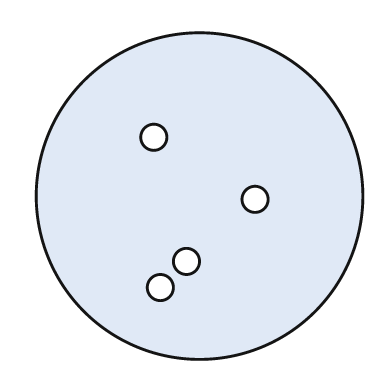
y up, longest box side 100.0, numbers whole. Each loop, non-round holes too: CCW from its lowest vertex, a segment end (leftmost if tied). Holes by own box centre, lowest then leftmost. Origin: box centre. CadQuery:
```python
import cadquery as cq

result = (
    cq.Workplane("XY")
    .moveTo(0.0, 0.0)
    .circle(50.0)
    .moveTo(-12.0, -28.0)
    .circle(4.0)
    .moveTo(-4.0, -20.0)
    .circle(4.0)
    .moveTo(17.0, -1.0)
    .circle(4.0)
    .moveTo(-14.0, 18.0)
    .circle(4.0)
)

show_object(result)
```